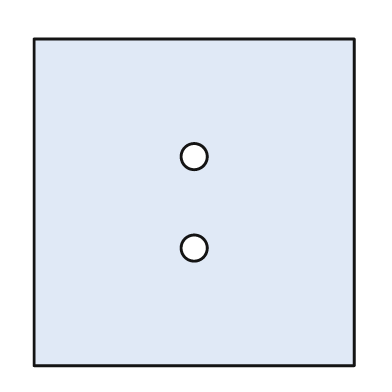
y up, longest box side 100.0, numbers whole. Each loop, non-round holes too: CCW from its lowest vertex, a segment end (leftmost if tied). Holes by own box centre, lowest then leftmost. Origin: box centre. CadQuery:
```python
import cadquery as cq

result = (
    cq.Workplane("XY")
    .moveTo(-49.0, -50.0)
    .lineTo(49.0, -50.0)
    .lineTo(49.0, 50.0)
    .lineTo(-49.0, 50.0)
    .close()
    .moveTo(0.0, -14.0)
    .circle(4.0)
    .moveTo(0.0, 14.0)
    .circle(4.0)
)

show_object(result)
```